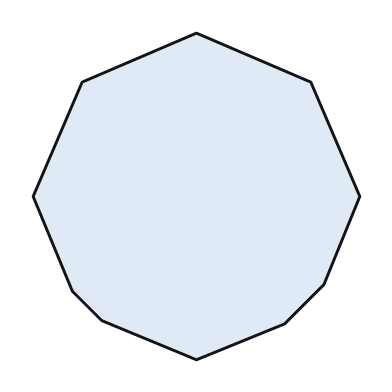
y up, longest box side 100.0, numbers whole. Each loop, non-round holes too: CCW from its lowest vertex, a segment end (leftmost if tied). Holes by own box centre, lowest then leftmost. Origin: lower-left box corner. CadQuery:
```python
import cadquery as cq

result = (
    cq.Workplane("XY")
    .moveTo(50.0, 0.0)
    .lineTo(77.0, 11.0)
    .lineTo(89.0, 23.0)
    .lineTo(100.0, 50.0)
    .lineTo(85.0, 85.0)
    .lineTo(50.0, 100.0)
    .lineTo(15.0, 85.0)
    .lineTo(0.0, 50.0)
    .lineTo(12.0, 21.0)
    .lineTo(21.0, 12.0)
    .close()
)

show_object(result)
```